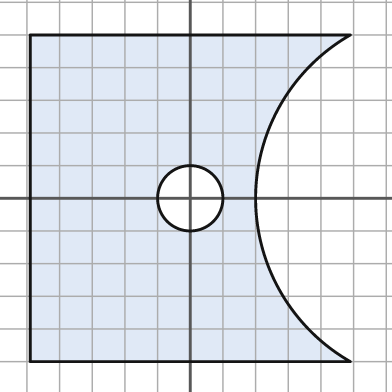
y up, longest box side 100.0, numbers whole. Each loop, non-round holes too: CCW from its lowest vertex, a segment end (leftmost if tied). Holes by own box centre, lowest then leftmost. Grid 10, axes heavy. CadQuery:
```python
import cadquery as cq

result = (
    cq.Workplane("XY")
    .moveTo(-49.0, -50.0)
    .lineTo(49.0, -50.0)
    .threePointArc((20.0, 0.0), (49.0, 50.0))
    .lineTo(-49.0, 50.0)
    .close()
    .moveTo(0.0, 0.0)
    .circle(10.0)
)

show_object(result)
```